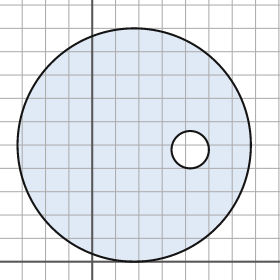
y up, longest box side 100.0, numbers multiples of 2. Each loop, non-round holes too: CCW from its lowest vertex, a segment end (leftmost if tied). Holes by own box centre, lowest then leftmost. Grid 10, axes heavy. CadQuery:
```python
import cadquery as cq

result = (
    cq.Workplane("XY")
    .moveTo(18.0, 50.0)
    .circle(50.0)
    .moveTo(42.0, 48.0)
    .circle(8.0)
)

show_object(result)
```